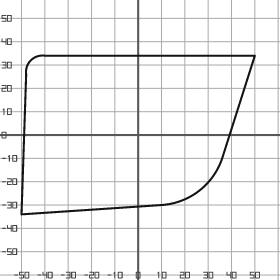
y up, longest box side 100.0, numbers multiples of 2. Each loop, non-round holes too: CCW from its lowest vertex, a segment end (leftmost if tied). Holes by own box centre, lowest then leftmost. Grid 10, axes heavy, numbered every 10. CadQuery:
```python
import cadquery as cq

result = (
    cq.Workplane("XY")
    .moveTo(-50.0, -34.0)
    .lineTo(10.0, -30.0)
    .threePointArc((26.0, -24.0), (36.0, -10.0))
    .lineTo(50.0, 34.0)
    .lineTo(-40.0, 34.0)
    .threePointArc((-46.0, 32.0), (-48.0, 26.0))
    .close()
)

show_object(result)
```